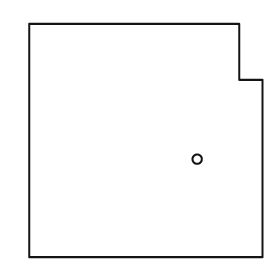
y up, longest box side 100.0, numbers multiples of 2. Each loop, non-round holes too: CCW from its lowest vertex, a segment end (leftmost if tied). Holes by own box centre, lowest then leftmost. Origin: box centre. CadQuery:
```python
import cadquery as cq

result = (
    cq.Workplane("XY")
    .moveTo(-50.0, -50.0)
    .lineTo(50.0, -50.0)
    .lineTo(50.0, 26.0)
    .lineTo(40.0, 26.0)
    .lineTo(40.0, 50.0)
    .lineTo(-50.0, 50.0)
    .close()
    .moveTo(22.0, -8.0)
    .circle(2.0)
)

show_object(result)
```